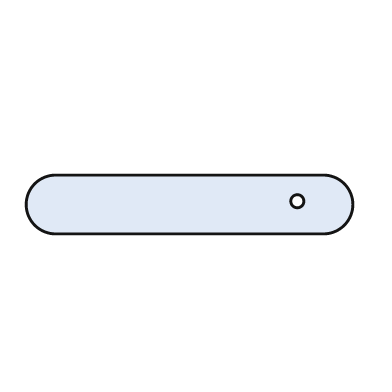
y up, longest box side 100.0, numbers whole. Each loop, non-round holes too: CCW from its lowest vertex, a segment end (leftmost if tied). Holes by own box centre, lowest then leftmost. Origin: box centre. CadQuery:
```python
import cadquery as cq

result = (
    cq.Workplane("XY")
    .moveTo(-41.0, -9.0)
    .lineTo(41.0, -9.0)
    .threePointArc((50.0, 0.0), (41.0, 9.0))
    .lineTo(-41.0, 9.0)
    .threePointArc((-50.0, 0.0), (-41.0, -9.0))
    .close()
    .moveTo(33.0, 1.0)
    .circle(2.0)
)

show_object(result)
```